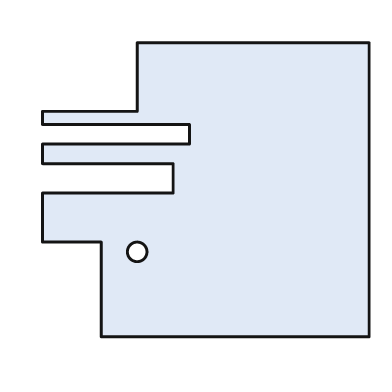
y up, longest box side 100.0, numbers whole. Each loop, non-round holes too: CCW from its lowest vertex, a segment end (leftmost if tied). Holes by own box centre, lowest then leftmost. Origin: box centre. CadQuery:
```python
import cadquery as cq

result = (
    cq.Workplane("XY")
    .moveTo(-32.0, -45.0)
    .lineTo(50.0, -45.0)
    .lineTo(50.0, 45.0)
    .lineTo(-21.0, 45.0)
    .lineTo(-21.0, 24.0)
    .lineTo(-50.0, 24.0)
    .lineTo(-50.0, 20.0)
    .lineTo(-5.0, 20.0)
    .lineTo(-5.0, 14.0)
    .lineTo(-50.0, 14.0)
    .lineTo(-50.0, 8.0)
    .lineTo(-10.0, 8.0)
    .lineTo(-10.0, -1.0)
    .lineTo(-50.0, -1.0)
    .lineTo(-50.0, -16.0)
    .lineTo(-32.0, -16.0)
    .close()
    .moveTo(-21.0, -19.0)
    .circle(3.0)
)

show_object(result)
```